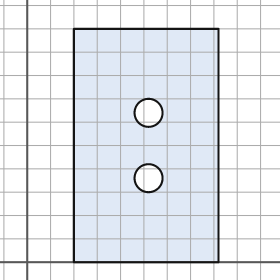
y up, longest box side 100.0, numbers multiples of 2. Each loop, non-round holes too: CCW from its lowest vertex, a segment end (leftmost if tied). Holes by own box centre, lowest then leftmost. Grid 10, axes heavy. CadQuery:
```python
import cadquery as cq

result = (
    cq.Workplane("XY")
    .moveTo(20.0, 0.0)
    .lineTo(82.0, 0.0)
    .lineTo(82.0, 100.0)
    .lineTo(20.0, 100.0)
    .close()
    .moveTo(52.0, 36.0)
    .circle(6.0)
    .moveTo(52.0, 64.0)
    .circle(6.0)
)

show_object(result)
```